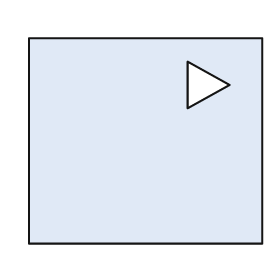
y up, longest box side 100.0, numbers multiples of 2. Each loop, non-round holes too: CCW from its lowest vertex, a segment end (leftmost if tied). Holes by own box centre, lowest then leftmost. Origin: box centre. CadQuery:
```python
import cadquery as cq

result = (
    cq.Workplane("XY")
    .moveTo(-50.0, -44.0)
    .lineTo(50.0, -44.0)
    .lineTo(50.0, 44.0)
    .lineTo(-50.0, 44.0)
    .close()
    .moveTo(18.0, 14.0)
    .lineTo(36.0, 24.0)
    .lineTo(18.0, 34.0)
    .close()
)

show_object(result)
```